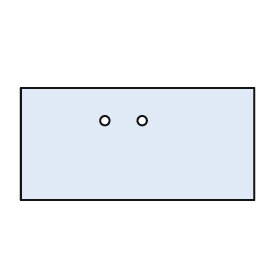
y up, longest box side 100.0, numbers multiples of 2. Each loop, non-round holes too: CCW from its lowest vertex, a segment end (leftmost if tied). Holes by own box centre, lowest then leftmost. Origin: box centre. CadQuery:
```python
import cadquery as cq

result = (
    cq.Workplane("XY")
    .moveTo(-50.0, -24.0)
    .lineTo(50.0, -24.0)
    .lineTo(50.0, 24.0)
    .lineTo(-50.0, 24.0)
    .close()
    .moveTo(-14.0, 10.0)
    .circle(2.0)
    .moveTo(2.0, 10.0)
    .circle(2.0)
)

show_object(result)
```